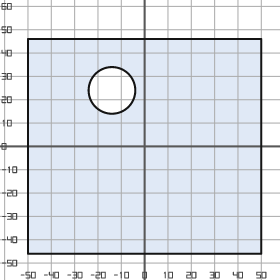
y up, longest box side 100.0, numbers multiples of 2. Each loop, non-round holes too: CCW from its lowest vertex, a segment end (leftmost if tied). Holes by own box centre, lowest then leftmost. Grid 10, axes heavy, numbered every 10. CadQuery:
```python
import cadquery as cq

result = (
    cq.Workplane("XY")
    .moveTo(-50.0, -46.0)
    .lineTo(50.0, -46.0)
    .lineTo(50.0, 46.0)
    .lineTo(-50.0, 46.0)
    .close()
    .moveTo(-14.0, 24.0)
    .circle(10.0)
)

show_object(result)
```